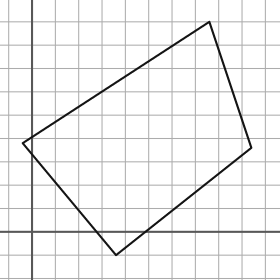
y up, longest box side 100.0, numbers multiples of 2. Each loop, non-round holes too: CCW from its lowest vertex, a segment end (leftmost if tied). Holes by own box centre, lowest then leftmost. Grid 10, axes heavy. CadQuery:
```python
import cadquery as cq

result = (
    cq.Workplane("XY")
    .moveTo(36.0, -10.0)
    .lineTo(94.0, 36.0)
    .lineTo(76.0, 90.0)
    .lineTo(-4.0, 38.0)
    .close()
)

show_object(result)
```